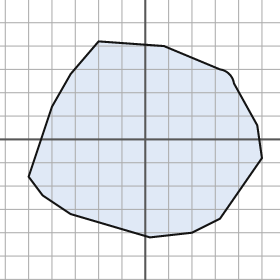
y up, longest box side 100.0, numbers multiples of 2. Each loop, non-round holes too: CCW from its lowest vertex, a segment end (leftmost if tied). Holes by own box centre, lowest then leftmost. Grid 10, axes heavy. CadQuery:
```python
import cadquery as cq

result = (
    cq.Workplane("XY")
    .moveTo(2.0, -42.0)
    .lineTo(20.0, -40.0)
    .lineTo(32.0, -34.0)
    .lineTo(50.0, -8.0)
    .lineTo(48.0, 6.0)
    .lineTo(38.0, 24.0)
    .threePointArc((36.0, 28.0), (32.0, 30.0))
    .lineTo(8.0, 40.0)
    .lineTo(-20.0, 42.0)
    .lineTo(-32.0, 28.0)
    .lineTo(-40.0, 14.0)
    .lineTo(-50.0, -16.0)
    .lineTo(-44.0, -24.0)
    .lineTo(-32.0, -32.0)
    .close()
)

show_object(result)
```